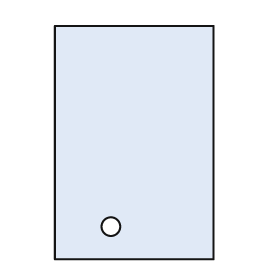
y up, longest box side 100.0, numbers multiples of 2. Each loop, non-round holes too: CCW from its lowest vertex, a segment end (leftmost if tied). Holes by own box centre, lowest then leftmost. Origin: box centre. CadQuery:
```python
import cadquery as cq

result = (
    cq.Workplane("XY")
    .moveTo(-34.0, -50.0)
    .lineTo(34.0, -50.0)
    .lineTo(34.0, 50.0)
    .lineTo(-34.0, 50.0)
    .close()
    .moveTo(-10.0, -36.0)
    .circle(4.0)
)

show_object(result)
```